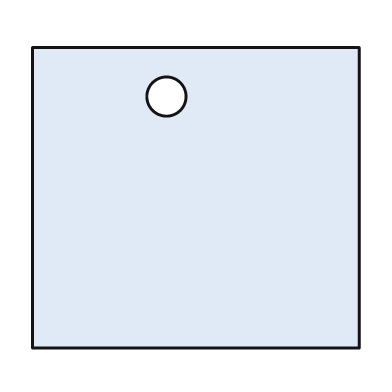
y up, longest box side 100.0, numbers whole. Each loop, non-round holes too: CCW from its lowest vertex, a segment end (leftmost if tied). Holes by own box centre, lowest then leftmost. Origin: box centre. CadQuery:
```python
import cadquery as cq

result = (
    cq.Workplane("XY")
    .moveTo(-50.0, -46.0)
    .lineTo(50.0, -46.0)
    .lineTo(50.0, 46.0)
    .lineTo(-50.0, 46.0)
    .close()
    .moveTo(-9.0, 31.0)
    .circle(6.0)
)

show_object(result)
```